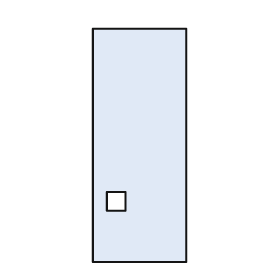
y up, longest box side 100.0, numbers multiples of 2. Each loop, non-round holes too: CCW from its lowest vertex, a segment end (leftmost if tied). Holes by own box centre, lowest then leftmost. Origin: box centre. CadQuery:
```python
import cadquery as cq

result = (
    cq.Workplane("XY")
    .moveTo(-20.0, -50.0)
    .lineTo(20.0, -50.0)
    .lineTo(20.0, 50.0)
    .lineTo(-20.0, 50.0)
    .close()
    .moveTo(-14.0, -28.0)
    .lineTo(-6.0, -28.0)
    .lineTo(-6.0, -20.0)
    .lineTo(-14.0, -20.0)
    .close()
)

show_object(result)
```